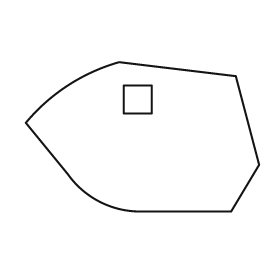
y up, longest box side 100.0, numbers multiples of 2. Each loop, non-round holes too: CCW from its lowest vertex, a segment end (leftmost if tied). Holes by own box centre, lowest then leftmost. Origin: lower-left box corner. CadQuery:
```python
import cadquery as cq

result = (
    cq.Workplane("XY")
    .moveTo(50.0, 0.0)
    .lineTo(88.0, 0.0)
    .lineTo(100.0, 20.0)
    .lineTo(90.0, 58.0)
    .lineTo(40.0, 64.0)
    .threePointArc((18.0, 54.0), (0.0, 38.0))
    .lineTo(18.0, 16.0)
    .threePointArc((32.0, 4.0), (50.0, 0.0))
    .close()
    .moveTo(42.0, 42.0)
    .lineTo(54.0, 42.0)
    .lineTo(54.0, 54.0)
    .lineTo(42.0, 54.0)
    .close()
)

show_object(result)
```